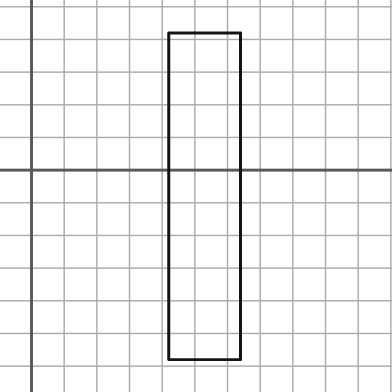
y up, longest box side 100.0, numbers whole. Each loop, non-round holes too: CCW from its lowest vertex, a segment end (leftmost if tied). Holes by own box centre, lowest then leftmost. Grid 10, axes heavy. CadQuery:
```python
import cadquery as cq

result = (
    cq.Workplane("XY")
    .moveTo(42.0, -58.0)
    .lineTo(64.0, -58.0)
    .lineTo(64.0, 42.0)
    .lineTo(42.0, 42.0)
    .close()
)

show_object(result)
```